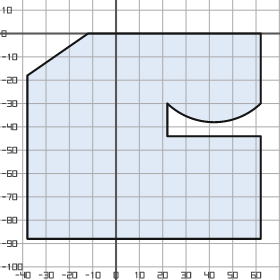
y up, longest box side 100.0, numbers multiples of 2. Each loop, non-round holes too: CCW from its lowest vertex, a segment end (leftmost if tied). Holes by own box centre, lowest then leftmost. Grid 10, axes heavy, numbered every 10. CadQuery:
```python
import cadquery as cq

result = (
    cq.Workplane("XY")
    .moveTo(-38.0, -88.0)
    .lineTo(62.0, -88.0)
    .lineTo(62.0, -44.0)
    .lineTo(22.0, -44.0)
    .lineTo(22.0, -30.0)
    .threePointArc((42.0, -38.0), (62.0, -30.0))
    .lineTo(62.0, 0.0)
    .lineTo(-12.0, 0.0)
    .lineTo(-38.0, -18.0)
    .close()
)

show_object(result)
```